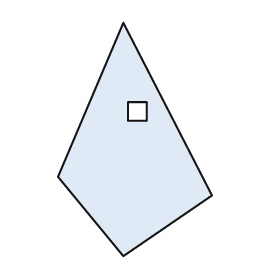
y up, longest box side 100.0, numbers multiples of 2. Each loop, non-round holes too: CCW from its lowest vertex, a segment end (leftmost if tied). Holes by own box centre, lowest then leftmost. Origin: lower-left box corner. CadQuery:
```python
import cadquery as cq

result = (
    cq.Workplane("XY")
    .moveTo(28.0, 0.0)
    .lineTo(66.0, 26.0)
    .lineTo(28.0, 100.0)
    .lineTo(0.0, 34.0)
    .close()
    .moveTo(30.0, 58.0)
    .lineTo(38.0, 58.0)
    .lineTo(38.0, 66.0)
    .lineTo(30.0, 66.0)
    .close()
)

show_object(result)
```